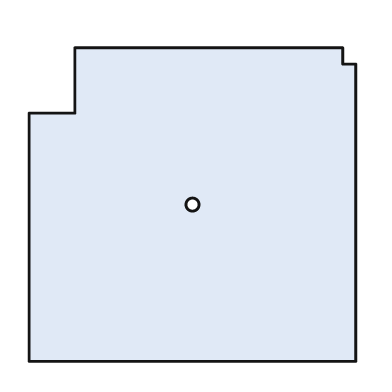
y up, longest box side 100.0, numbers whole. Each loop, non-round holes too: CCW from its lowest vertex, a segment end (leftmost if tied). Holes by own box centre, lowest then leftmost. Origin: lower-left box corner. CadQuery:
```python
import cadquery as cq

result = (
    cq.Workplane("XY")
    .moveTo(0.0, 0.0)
    .lineTo(100.0, 0.0)
    .lineTo(100.0, 91.0)
    .lineTo(96.0, 91.0)
    .lineTo(96.0, 96.0)
    .lineTo(14.0, 96.0)
    .lineTo(14.0, 76.0)
    .lineTo(0.0, 76.0)
    .close()
    .moveTo(50.0, 48.0)
    .circle(2.0)
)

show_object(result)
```